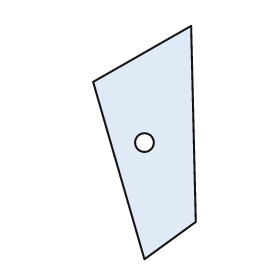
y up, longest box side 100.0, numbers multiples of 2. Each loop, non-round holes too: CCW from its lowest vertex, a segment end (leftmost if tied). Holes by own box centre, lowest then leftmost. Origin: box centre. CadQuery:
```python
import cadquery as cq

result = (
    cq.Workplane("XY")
    .moveTo(0.0, -50.0)
    .lineTo(22.0, -34.0)
    .lineTo(20.0, 50.0)
    .lineTo(-22.0, 26.0)
    .close()
    .moveTo(0.0, 0.0)
    .circle(4.0)
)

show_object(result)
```